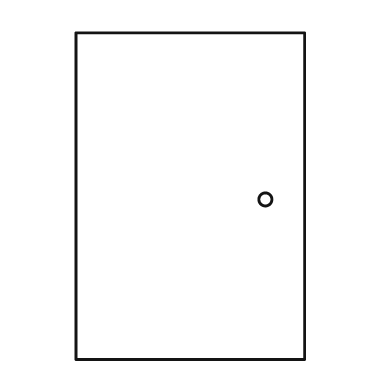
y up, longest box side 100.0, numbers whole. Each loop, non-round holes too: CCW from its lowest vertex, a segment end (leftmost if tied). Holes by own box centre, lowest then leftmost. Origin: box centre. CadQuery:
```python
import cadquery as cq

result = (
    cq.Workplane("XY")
    .moveTo(-35.0, -50.0)
    .lineTo(35.0, -50.0)
    .lineTo(35.0, 50.0)
    .lineTo(-35.0, 50.0)
    .close()
    .moveTo(23.0, -1.0)
    .circle(2.0)
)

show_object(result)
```